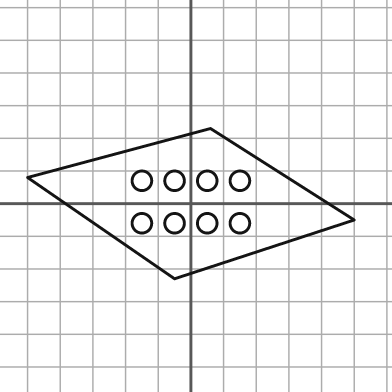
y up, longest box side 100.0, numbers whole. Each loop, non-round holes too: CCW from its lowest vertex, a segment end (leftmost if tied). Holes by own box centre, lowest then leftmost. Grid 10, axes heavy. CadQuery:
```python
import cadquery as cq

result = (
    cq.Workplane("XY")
    .moveTo(-5.0, -23.0)
    .lineTo(50.0, -5.0)
    .lineTo(6.0, 23.0)
    .lineTo(-50.0, 8.0)
    .close()
    .moveTo(-15.0, -6.0)
    .circle(3.0)
    .moveTo(-5.0, -6.0)
    .circle(3.0)
    .moveTo(5.0, -6.0)
    .circle(3.0)
    .moveTo(15.0, -6.0)
    .circle(3.0)
    .moveTo(-15.0, 7.0)
    .circle(3.0)
    .moveTo(-5.0, 7.0)
    .circle(3.0)
    .moveTo(5.0, 7.0)
    .circle(3.0)
    .moveTo(15.0, 7.0)
    .circle(3.0)
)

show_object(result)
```